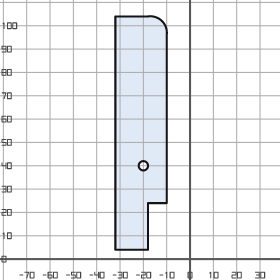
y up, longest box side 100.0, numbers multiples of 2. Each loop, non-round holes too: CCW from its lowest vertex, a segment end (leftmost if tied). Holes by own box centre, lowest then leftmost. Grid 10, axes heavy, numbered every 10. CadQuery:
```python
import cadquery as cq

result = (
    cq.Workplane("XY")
    .moveTo(-32.0, 4.0)
    .lineTo(-18.0, 4.0)
    .lineTo(-18.0, 24.0)
    .lineTo(-10.0, 24.0)
    .lineTo(-10.0, 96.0)
    .threePointArc((-12.0, 102.0), (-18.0, 104.0))
    .lineTo(-32.0, 104.0)
    .close()
    .moveTo(-20.0, 40.0)
    .circle(2.0)
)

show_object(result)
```